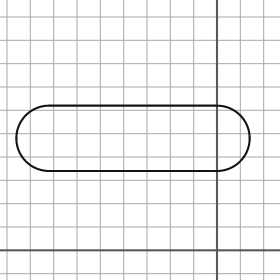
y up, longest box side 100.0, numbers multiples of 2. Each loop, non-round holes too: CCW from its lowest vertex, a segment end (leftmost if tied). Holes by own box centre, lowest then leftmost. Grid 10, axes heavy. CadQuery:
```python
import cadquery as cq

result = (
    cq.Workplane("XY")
    .moveTo(-72.0, 34.0)
    .lineTo(0.0, 34.0)
    .threePointArc((14.0, 48.0), (0.0, 62.0))
    .lineTo(-72.0, 62.0)
    .threePointArc((-86.0, 48.0), (-72.0, 34.0))
    .close()
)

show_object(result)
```